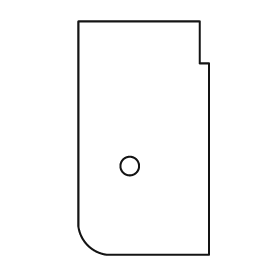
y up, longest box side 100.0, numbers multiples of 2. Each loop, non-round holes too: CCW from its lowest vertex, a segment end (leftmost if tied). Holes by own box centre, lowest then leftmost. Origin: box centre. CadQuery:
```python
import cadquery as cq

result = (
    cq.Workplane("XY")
    .moveTo(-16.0, -50.0)
    .lineTo(28.0, -50.0)
    .lineTo(28.0, 32.0)
    .lineTo(24.0, 32.0)
    .lineTo(24.0, 50.0)
    .lineTo(-28.0, 50.0)
    .lineTo(-28.0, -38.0)
    .threePointArc((-24.0, -46.0), (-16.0, -50.0))
    .close()
    .moveTo(-6.0, -12.0)
    .circle(4.0)
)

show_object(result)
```